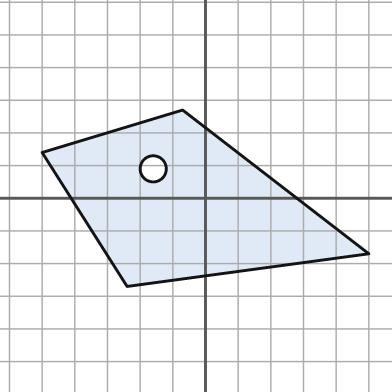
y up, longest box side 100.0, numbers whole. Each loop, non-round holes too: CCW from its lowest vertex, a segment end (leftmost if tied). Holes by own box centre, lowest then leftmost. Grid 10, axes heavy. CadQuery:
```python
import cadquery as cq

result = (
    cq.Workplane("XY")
    .moveTo(-24.0, -27.0)
    .lineTo(50.0, -17.0)
    .lineTo(-7.0, 27.0)
    .lineTo(-50.0, 14.0)
    .close()
    .moveTo(-16.0, 9.0)
    .circle(4.0)
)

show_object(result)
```